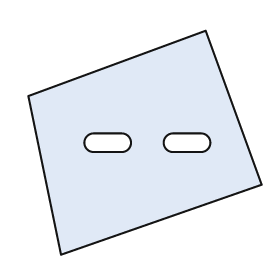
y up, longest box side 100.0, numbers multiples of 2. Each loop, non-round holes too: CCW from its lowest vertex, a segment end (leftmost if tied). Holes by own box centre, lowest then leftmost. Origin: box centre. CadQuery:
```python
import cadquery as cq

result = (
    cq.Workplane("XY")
    .moveTo(-36.0, -48.0)
    .lineTo(50.0, -18.0)
    .lineTo(26.0, 48.0)
    .lineTo(-50.0, 20.0)
    .close()
    .moveTo(-22.0, -4.0)
    .lineTo(-10.0, -4.0)
    .threePointArc((-6.0, 0.0), (-10.0, 4.0))
    .lineTo(-22.0, 4.0)
    .threePointArc((-26.0, 0.0), (-22.0, -4.0))
    .close()
    .moveTo(12.0, -4.0)
    .lineTo(24.0, -4.0)
    .threePointArc((28.0, 0.0), (24.0, 4.0))
    .lineTo(12.0, 4.0)
    .threePointArc((8.0, 0.0), (12.0, -4.0))
    .close()
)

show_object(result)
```